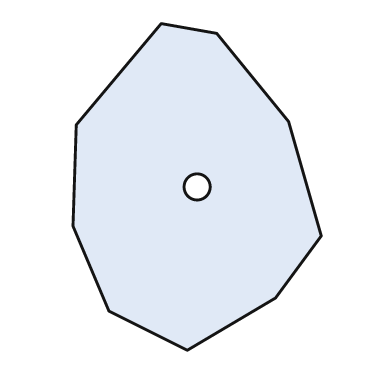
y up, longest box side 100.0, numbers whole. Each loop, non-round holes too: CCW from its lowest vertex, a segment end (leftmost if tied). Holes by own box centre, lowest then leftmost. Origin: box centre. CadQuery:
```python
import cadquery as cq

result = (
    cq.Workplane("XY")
    .moveTo(-3.0, -50.0)
    .lineTo(24.0, -34.0)
    .lineTo(38.0, -15.0)
    .lineTo(28.0, 20.0)
    .lineTo(6.0, 47.0)
    .lineTo(-11.0, 50.0)
    .lineTo(-37.0, 19.0)
    .lineTo(-38.0, -12.0)
    .lineTo(-27.0, -38.0)
    .close()
    .moveTo(0.0, 0.0)
    .circle(4.0)
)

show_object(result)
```